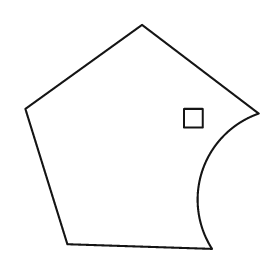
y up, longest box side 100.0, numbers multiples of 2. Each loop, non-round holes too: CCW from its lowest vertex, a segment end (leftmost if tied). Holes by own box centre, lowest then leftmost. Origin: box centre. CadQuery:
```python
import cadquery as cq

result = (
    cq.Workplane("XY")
    .moveTo(30.0, -48.0)
    .threePointArc((26.0, -14.0), (50.0, 10.0))
    .lineTo(0.0, 48.0)
    .lineTo(-50.0, 12.0)
    .lineTo(-32.0, -46.0)
    .close()
    .moveTo(18.0, 4.0)
    .lineTo(26.0, 4.0)
    .lineTo(26.0, 12.0)
    .lineTo(18.0, 12.0)
    .close()
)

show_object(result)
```